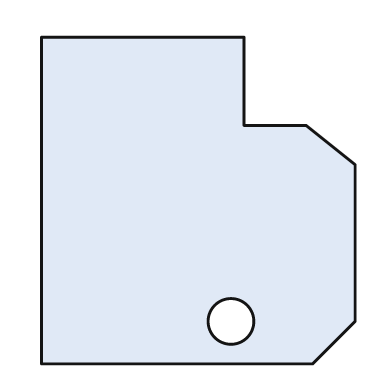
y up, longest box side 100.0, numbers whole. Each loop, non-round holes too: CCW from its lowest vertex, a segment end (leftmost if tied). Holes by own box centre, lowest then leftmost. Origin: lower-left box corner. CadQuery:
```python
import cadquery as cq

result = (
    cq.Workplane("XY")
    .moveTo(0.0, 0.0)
    .lineTo(83.0, 0.0)
    .lineTo(96.0, 13.0)
    .lineTo(96.0, 61.0)
    .lineTo(81.0, 73.0)
    .lineTo(62.0, 73.0)
    .lineTo(62.0, 100.0)
    .lineTo(0.0, 100.0)
    .close()
    .moveTo(58.0, 13.0)
    .circle(7.0)
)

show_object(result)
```